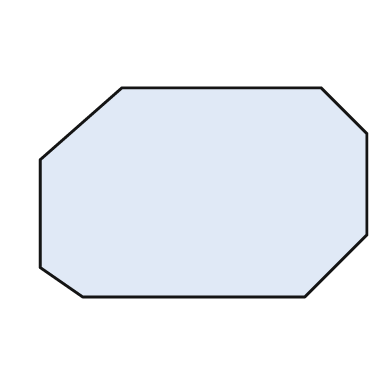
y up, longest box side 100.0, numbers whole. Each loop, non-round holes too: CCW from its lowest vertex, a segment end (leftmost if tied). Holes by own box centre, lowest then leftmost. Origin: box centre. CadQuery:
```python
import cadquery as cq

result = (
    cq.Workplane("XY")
    .moveTo(-37.0, -32.0)
    .lineTo(31.0, -32.0)
    .lineTo(50.0, -13.0)
    .lineTo(50.0, 18.0)
    .lineTo(36.0, 32.0)
    .lineTo(-25.0, 32.0)
    .lineTo(-50.0, 10.0)
    .lineTo(-50.0, -23.0)
    .close()
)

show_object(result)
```